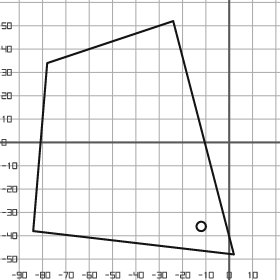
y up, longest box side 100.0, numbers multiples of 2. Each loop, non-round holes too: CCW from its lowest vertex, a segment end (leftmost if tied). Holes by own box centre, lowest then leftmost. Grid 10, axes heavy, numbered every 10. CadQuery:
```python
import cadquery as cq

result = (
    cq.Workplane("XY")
    .moveTo(2.0, -48.0)
    .lineTo(-24.0, 52.0)
    .lineTo(-78.0, 34.0)
    .lineTo(-84.0, -38.0)
    .close()
    .moveTo(-12.0, -36.0)
    .circle(2.0)
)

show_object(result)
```